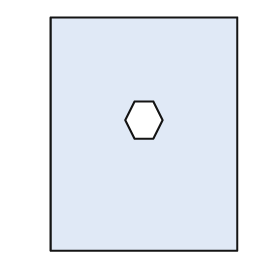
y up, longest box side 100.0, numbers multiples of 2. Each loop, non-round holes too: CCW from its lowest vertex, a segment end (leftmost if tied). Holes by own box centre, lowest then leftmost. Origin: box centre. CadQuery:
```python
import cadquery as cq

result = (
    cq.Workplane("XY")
    .moveTo(-40.0, -50.0)
    .lineTo(40.0, -50.0)
    .lineTo(40.0, 50.0)
    .lineTo(-40.0, 50.0)
    .close()
    .moveTo(-4.0, -2.0)
    .lineTo(4.0, -2.0)
    .lineTo(8.0, 6.0)
    .lineTo(4.0, 14.0)
    .lineTo(-4.0, 14.0)
    .lineTo(-8.0, 6.0)
    .close()
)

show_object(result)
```